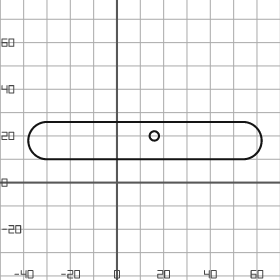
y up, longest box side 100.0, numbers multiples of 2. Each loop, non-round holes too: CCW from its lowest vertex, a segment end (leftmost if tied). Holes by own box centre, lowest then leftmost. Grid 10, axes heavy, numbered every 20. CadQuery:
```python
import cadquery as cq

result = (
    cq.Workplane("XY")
    .moveTo(-30.0, 10.0)
    .lineTo(54.0, 10.0)
    .threePointArc((62.0, 18.0), (54.0, 26.0))
    .lineTo(-30.0, 26.0)
    .threePointArc((-38.0, 18.0), (-30.0, 10.0))
    .close()
    .moveTo(16.0, 20.0)
    .circle(2.0)
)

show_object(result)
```